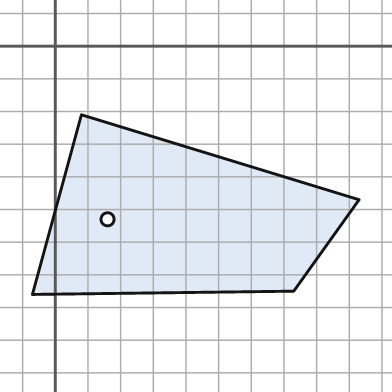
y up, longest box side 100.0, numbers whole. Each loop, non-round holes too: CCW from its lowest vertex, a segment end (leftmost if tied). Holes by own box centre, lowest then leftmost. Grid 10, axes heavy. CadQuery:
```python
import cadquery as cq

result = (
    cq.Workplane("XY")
    .moveTo(-7.0, -76.0)
    .lineTo(73.0, -75.0)
    .lineTo(93.0, -47.0)
    .lineTo(8.0, -21.0)
    .close()
    .moveTo(16.0, -53.0)
    .circle(2.0)
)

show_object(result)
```